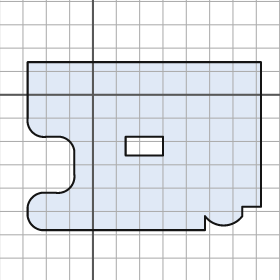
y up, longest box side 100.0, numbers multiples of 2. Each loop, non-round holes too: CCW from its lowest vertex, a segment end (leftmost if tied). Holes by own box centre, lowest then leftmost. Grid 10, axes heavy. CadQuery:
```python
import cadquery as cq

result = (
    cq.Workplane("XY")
    .moveTo(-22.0, -58.0)
    .lineTo(48.0, -58.0)
    .lineTo(48.0, -52.0)
    .threePointArc((56.0, -56.0), (64.0, -52.0))
    .lineTo(64.0, -48.0)
    .lineTo(72.0, -48.0)
    .lineTo(72.0, 14.0)
    .lineTo(-28.0, 14.0)
    .lineTo(-28.0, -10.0)
    .threePointArc((-26.0, -16.0), (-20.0, -18.0))
    .lineTo(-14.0, -18.0)
    .threePointArc((-10.0, -20.0), (-8.0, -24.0))
    .lineTo(-8.0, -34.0)
    .threePointArc((-10.0, -40.0), (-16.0, -42.0))
    .lineTo(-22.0, -42.0)
    .threePointArc((-26.0, -44.0), (-28.0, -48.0))
    .lineTo(-28.0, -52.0)
    .threePointArc((-26.0, -56.0), (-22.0, -58.0))
    .close()
    .moveTo(14.0, -26.0)
    .lineTo(30.0, -26.0)
    .lineTo(30.0, -18.0)
    .lineTo(14.0, -18.0)
    .close()
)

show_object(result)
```